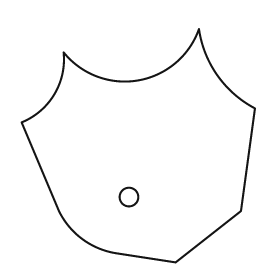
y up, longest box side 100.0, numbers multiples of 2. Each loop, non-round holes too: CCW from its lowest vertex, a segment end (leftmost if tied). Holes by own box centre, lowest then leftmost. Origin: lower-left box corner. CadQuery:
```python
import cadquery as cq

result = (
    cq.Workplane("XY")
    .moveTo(66.0, 0.0)
    .lineTo(94.0, 22.0)
    .lineTo(100.0, 66.0)
    .threePointArc((84.0, 80.0), (76.0, 100.0))
    .threePointArc((50.0, 78.0), (18.0, 90.0))
    .threePointArc((14.0, 72.0), (0.0, 60.0))
    .lineTo(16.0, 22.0)
    .threePointArc((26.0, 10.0), (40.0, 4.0))
    .close()
    .moveTo(46.0, 28.0)
    .circle(4.0)
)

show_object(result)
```